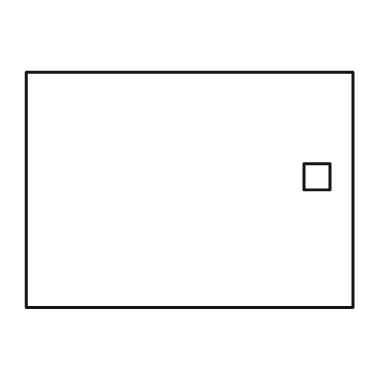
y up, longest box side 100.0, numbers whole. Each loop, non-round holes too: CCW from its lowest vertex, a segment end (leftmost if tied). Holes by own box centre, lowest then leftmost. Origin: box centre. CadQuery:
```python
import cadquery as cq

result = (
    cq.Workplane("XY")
    .moveTo(-50.0, -36.0)
    .lineTo(50.0, -36.0)
    .lineTo(50.0, 36.0)
    .lineTo(-50.0, 36.0)
    .close()
    .moveTo(35.0, 0.0)
    .lineTo(43.0, 0.0)
    .lineTo(43.0, 8.0)
    .lineTo(35.0, 8.0)
    .close()
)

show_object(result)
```